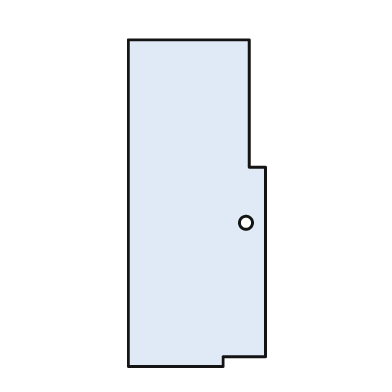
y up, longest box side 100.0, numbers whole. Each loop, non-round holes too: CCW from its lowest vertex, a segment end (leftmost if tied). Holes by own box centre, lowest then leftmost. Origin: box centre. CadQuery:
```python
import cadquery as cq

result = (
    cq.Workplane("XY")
    .moveTo(-21.0, -50.0)
    .lineTo(8.0, -50.0)
    .lineTo(8.0, -47.0)
    .lineTo(21.0, -47.0)
    .lineTo(21.0, 11.0)
    .lineTo(16.0, 11.0)
    .lineTo(16.0, 50.0)
    .lineTo(-21.0, 50.0)
    .close()
    .moveTo(15.0, -6.0)
    .circle(2.0)
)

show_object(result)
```